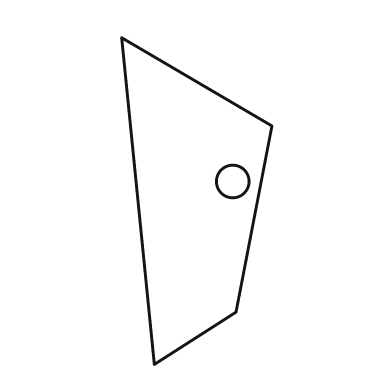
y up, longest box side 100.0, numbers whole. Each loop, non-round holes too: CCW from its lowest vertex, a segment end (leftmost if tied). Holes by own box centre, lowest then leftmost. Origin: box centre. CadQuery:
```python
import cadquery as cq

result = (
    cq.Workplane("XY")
    .moveTo(-13.0, -50.0)
    .lineTo(12.0, -34.0)
    .lineTo(23.0, 23.0)
    .lineTo(-23.0, 50.0)
    .close()
    .moveTo(11.0, 6.0)
    .circle(5.0)
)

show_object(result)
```